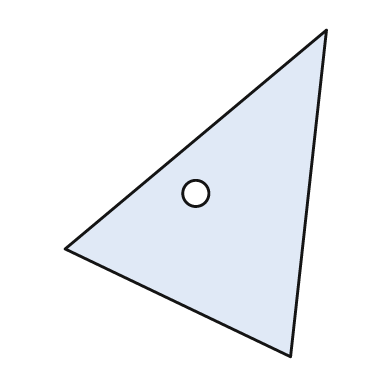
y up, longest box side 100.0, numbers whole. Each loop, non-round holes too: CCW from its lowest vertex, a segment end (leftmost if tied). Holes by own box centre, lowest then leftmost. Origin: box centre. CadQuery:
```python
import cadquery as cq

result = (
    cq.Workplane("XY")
    .moveTo(29.0, -50.0)
    .lineTo(40.0, 50.0)
    .lineTo(-40.0, -17.0)
    .close()
    .moveTo(0.0, 0.0)
    .circle(4.0)
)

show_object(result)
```